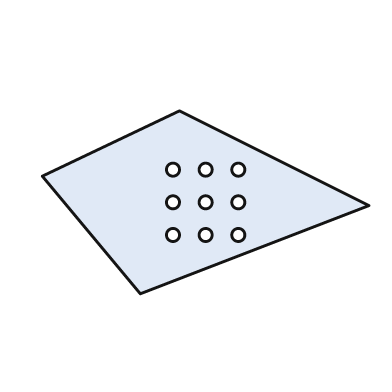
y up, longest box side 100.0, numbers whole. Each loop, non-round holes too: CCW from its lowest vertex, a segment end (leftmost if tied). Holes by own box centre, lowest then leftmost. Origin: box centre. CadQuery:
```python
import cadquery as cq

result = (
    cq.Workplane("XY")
    .moveTo(-20.0, -28.0)
    .lineTo(50.0, -1.0)
    .lineTo(-8.0, 28.0)
    .lineTo(-50.0, 8.0)
    .close()
    .moveTo(-10.0, -10.0)
    .circle(2.0)
    .moveTo(0.0, -10.0)
    .circle(2.0)
    .moveTo(10.0, -10.0)
    .circle(2.0)
    .moveTo(-10.0, 0.0)
    .circle(2.0)
    .moveTo(0.0, 0.0)
    .circle(2.0)
    .moveTo(10.0, 0.0)
    .circle(2.0)
    .moveTo(-10.0, 10.0)
    .circle(2.0)
    .moveTo(0.0, 10.0)
    .circle(2.0)
    .moveTo(10.0, 10.0)
    .circle(2.0)
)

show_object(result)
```